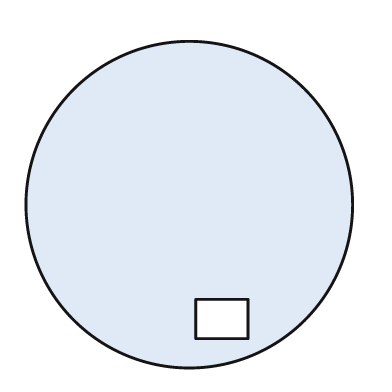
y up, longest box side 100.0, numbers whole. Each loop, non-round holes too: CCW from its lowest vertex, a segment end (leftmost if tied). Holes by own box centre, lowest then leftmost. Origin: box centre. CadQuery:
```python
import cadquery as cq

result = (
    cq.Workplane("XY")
    .moveTo(0.0, 0.0)
    .circle(50.0)
    .moveTo(2.0, -41.0)
    .lineTo(18.0, -41.0)
    .lineTo(18.0, -29.0)
    .lineTo(2.0, -29.0)
    .close()
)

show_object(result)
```